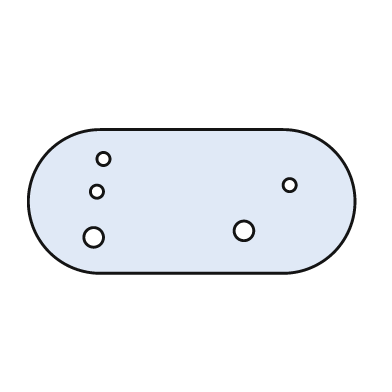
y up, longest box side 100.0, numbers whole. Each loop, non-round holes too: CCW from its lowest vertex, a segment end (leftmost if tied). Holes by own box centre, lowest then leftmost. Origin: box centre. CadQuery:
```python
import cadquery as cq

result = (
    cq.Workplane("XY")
    .moveTo(-28.0, -22.0)
    .lineTo(28.0, -22.0)
    .threePointArc((50.0, 0.0), (28.0, 22.0))
    .lineTo(-28.0, 22.0)
    .threePointArc((-50.0, 0.0), (-28.0, -22.0))
    .close()
    .moveTo(-30.0, -11.0)
    .circle(3.0)
    .moveTo(16.0, -9.0)
    .circle(3.0)
    .moveTo(-29.0, 3.0)
    .circle(2.0)
    .moveTo(30.0, 5.0)
    .circle(2.0)
    .moveTo(-27.0, 13.0)
    .circle(2.0)
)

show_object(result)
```